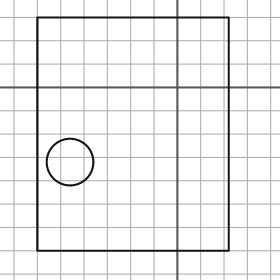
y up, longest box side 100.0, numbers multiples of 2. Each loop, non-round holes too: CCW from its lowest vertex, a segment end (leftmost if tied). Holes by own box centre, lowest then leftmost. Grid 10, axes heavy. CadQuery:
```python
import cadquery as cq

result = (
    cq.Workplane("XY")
    .moveTo(-60.0, -70.0)
    .lineTo(22.0, -70.0)
    .lineTo(22.0, 30.0)
    .lineTo(-60.0, 30.0)
    .close()
    .moveTo(-46.0, -32.0)
    .circle(10.0)
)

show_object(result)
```